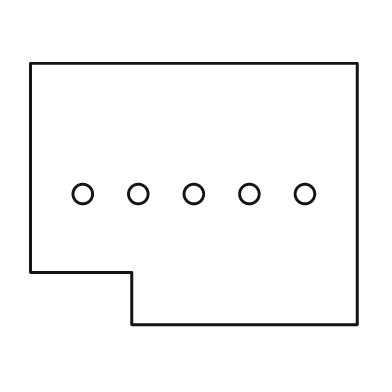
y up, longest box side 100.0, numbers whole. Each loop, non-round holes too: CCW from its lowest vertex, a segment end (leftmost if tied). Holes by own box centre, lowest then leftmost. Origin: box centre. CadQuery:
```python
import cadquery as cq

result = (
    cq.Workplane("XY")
    .moveTo(-19.0, -40.0)
    .lineTo(50.0, -40.0)
    .lineTo(50.0, 40.0)
    .lineTo(-50.0, 40.0)
    .lineTo(-50.0, -24.0)
    .lineTo(-19.0, -24.0)
    .close()
    .moveTo(-34.0, 0.0)
    .circle(3.0)
    .moveTo(-17.0, 0.0)
    .circle(3.0)
    .moveTo(0.0, 0.0)
    .circle(3.0)
    .moveTo(17.0, 0.0)
    .circle(3.0)
    .moveTo(34.0, 0.0)
    .circle(3.0)
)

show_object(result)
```